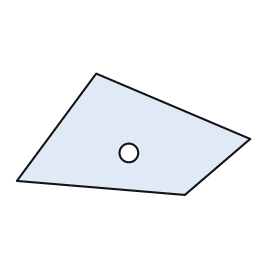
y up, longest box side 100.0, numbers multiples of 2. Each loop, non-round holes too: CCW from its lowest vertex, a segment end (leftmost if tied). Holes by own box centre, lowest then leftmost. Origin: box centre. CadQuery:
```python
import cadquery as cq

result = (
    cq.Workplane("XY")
    .moveTo(22.0, -26.0)
    .lineTo(50.0, -2.0)
    .lineTo(-16.0, 26.0)
    .lineTo(-50.0, -20.0)
    .close()
    .moveTo(-2.0, -8.0)
    .circle(4.0)
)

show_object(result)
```